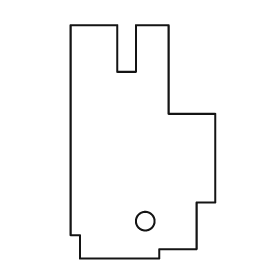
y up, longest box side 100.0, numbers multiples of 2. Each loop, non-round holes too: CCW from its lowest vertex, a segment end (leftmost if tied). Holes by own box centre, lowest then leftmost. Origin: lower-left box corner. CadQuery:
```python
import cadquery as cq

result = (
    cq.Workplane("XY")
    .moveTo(4.0, 0.0)
    .lineTo(38.0, 0.0)
    .lineTo(38.0, 4.0)
    .lineTo(54.0, 4.0)
    .lineTo(54.0, 24.0)
    .lineTo(62.0, 24.0)
    .lineTo(62.0, 62.0)
    .lineTo(42.0, 62.0)
    .lineTo(42.0, 100.0)
    .lineTo(28.0, 100.0)
    .lineTo(28.0, 80.0)
    .lineTo(20.0, 80.0)
    .lineTo(20.0, 100.0)
    .lineTo(0.0, 100.0)
    .lineTo(0.0, 10.0)
    .lineTo(4.0, 10.0)
    .close()
    .moveTo(32.0, 16.0)
    .circle(4.0)
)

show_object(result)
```